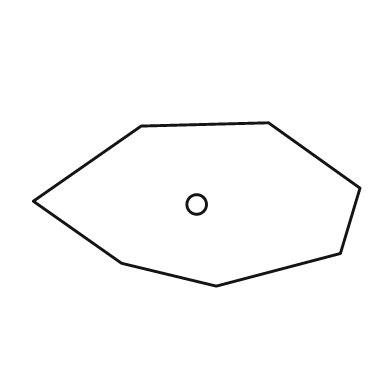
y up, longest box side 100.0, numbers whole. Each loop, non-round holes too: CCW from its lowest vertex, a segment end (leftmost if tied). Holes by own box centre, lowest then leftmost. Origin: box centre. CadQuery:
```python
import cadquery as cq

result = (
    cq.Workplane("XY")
    .moveTo(6.0, -25.0)
    .lineTo(44.0, -15.0)
    .lineTo(50.0, 5.0)
    .lineTo(22.0, 25.0)
    .lineTo(-17.0, 24.0)
    .lineTo(-50.0, 1.0)
    .lineTo(-23.0, -18.0)
    .close()
    .moveTo(0.0, 0.0)
    .circle(3.0)
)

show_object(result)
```